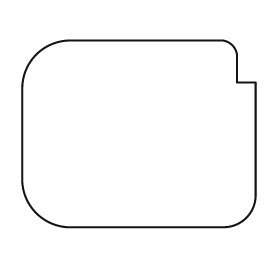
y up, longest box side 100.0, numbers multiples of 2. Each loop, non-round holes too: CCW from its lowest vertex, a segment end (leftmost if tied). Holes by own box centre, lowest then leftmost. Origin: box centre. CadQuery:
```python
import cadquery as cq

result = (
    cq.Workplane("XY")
    .moveTo(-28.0, -40.0)
    .lineTo(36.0, -40.0)
    .threePointArc((46.0, -36.0), (50.0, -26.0))
    .lineTo(50.0, 22.0)
    .lineTo(42.0, 22.0)
    .lineTo(42.0, 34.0)
    .threePointArc((40.0, 38.0), (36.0, 40.0))
    .lineTo(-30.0, 40.0)
    .threePointArc((-44.0, 34.0), (-50.0, 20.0))
    .lineTo(-50.0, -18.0)
    .threePointArc((-44.0, -34.0), (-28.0, -40.0))
    .close()
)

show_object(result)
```